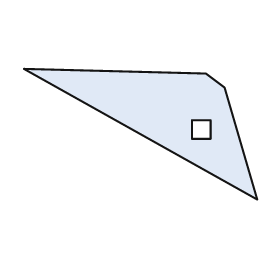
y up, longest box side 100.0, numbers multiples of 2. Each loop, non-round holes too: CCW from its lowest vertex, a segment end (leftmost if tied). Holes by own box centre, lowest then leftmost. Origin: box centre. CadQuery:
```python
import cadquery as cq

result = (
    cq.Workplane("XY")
    .moveTo(50.0, -28.0)
    .lineTo(36.0, 20.0)
    .lineTo(28.0, 26.0)
    .lineTo(-50.0, 28.0)
    .close()
    .moveTo(22.0, -2.0)
    .lineTo(30.0, -2.0)
    .lineTo(30.0, 6.0)
    .lineTo(22.0, 6.0)
    .close()
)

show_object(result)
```